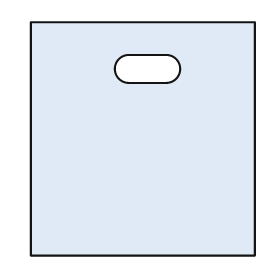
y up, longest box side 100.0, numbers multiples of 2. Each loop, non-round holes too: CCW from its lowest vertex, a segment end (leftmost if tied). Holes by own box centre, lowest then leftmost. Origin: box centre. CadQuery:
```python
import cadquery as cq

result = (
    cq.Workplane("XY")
    .moveTo(-48.0, -50.0)
    .lineTo(48.0, -50.0)
    .lineTo(48.0, 50.0)
    .lineTo(-48.0, 50.0)
    .close()
    .moveTo(-6.0, 24.0)
    .lineTo(10.0, 24.0)
    .threePointArc((16.0, 30.0), (10.0, 36.0))
    .lineTo(-6.0, 36.0)
    .threePointArc((-12.0, 30.0), (-6.0, 24.0))
    .close()
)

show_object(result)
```